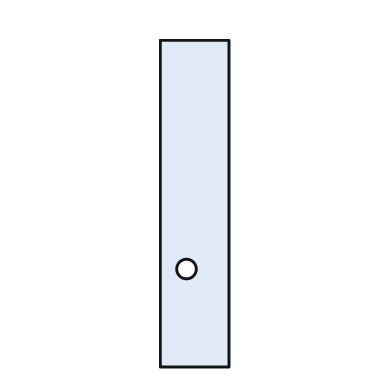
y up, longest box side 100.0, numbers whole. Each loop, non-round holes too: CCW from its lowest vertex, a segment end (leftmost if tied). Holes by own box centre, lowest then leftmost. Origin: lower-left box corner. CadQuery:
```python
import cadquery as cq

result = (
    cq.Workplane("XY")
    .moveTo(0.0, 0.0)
    .lineTo(21.0, 0.0)
    .lineTo(21.0, 100.0)
    .lineTo(0.0, 100.0)
    .close()
    .moveTo(8.0, 30.0)
    .circle(3.0)
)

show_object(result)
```